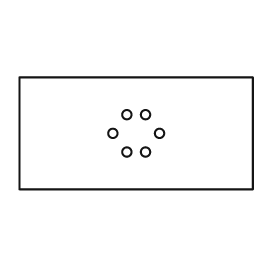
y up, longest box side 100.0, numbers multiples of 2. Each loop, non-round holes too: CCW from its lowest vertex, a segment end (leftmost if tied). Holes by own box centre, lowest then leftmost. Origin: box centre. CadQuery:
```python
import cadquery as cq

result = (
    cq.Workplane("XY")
    .moveTo(-50.0, -24.0)
    .lineTo(50.0, -24.0)
    .lineTo(50.0, 24.0)
    .lineTo(-50.0, 24.0)
    .close()
    .moveTo(-4.0, -8.0)
    .circle(2.0)
    .moveTo(4.0, -8.0)
    .circle(2.0)
    .moveTo(-10.0, 0.0)
    .circle(2.0)
    .moveTo(10.0, 0.0)
    .circle(2.0)
    .moveTo(-4.0, 8.0)
    .circle(2.0)
    .moveTo(4.0, 8.0)
    .circle(2.0)
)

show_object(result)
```